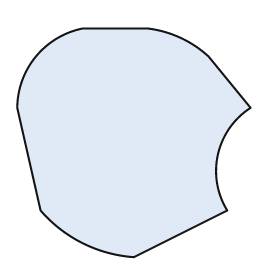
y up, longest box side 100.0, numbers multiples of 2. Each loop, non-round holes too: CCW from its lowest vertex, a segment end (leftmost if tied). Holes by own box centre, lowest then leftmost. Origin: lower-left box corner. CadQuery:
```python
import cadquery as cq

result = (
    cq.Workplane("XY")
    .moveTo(50.0, 0.0)
    .lineTo(90.0, 20.0)
    .threePointArc((86.0, 44.0), (100.0, 64.0))
    .lineTo(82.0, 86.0)
    .threePointArc((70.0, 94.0), (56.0, 98.0))
    .lineTo(28.0, 98.0)
    .threePointArc((8.0, 86.0), (0.0, 64.0))
    .lineTo(10.0, 20.0)
    .threePointArc((28.0, 6.0), (50.0, 0.0))
    .close()
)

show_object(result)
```